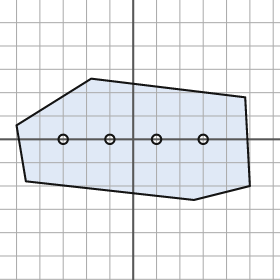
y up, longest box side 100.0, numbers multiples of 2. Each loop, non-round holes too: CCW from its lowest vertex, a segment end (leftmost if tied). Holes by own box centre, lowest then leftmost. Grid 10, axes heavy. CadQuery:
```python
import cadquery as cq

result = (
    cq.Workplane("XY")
    .moveTo(26.0, -26.0)
    .lineTo(50.0, -20.0)
    .lineTo(48.0, 18.0)
    .lineTo(-18.0, 26.0)
    .lineTo(-50.0, 6.0)
    .lineTo(-46.0, -18.0)
    .close()
    .moveTo(-30.0, 0.0)
    .circle(2.0)
    .moveTo(-10.0, 0.0)
    .circle(2.0)
    .moveTo(10.0, 0.0)
    .circle(2.0)
    .moveTo(30.0, 0.0)
    .circle(2.0)
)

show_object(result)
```